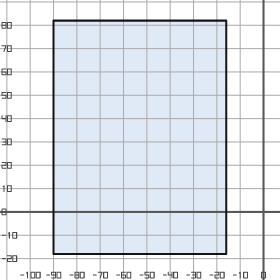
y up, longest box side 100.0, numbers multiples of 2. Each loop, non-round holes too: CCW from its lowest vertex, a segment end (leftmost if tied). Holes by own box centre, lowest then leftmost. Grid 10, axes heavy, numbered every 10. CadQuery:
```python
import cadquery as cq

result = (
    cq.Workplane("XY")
    .moveTo(-90.0, -18.0)
    .lineTo(-16.0, -18.0)
    .lineTo(-16.0, 82.0)
    .lineTo(-90.0, 82.0)
    .close()
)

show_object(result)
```